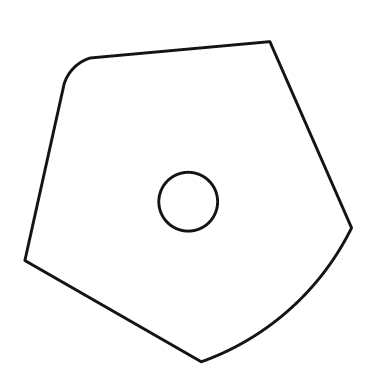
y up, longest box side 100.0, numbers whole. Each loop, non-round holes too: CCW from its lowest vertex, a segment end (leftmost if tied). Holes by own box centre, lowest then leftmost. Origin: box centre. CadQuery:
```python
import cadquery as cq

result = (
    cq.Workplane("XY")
    .moveTo(4.0, -49.0)
    .threePointArc((31.0, -33.0), (50.0, -8.0))
    .lineTo(25.0, 49.0)
    .lineTo(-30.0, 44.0)
    .threePointArc((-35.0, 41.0), (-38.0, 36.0))
    .lineTo(-50.0, -18.0)
    .close()
    .moveTo(0.0, 0.0)
    .circle(9.0)
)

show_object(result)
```